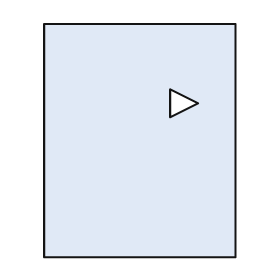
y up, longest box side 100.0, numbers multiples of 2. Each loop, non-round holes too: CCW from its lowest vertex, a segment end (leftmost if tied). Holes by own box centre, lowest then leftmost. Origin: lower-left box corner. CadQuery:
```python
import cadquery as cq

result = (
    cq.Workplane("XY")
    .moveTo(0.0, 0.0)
    .lineTo(82.0, 0.0)
    .lineTo(82.0, 100.0)
    .lineTo(0.0, 100.0)
    .close()
    .moveTo(54.0, 60.0)
    .lineTo(66.0, 66.0)
    .lineTo(54.0, 72.0)
    .close()
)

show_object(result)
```